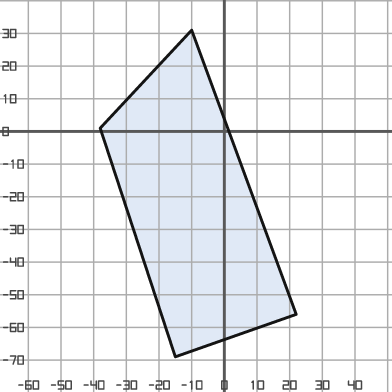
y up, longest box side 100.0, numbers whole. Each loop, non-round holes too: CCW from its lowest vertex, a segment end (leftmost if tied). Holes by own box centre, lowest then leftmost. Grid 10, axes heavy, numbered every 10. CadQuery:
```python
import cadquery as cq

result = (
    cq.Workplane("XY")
    .moveTo(-15.0, -69.0)
    .lineTo(22.0, -56.0)
    .lineTo(-10.0, 31.0)
    .lineTo(-38.0, 1.0)
    .close()
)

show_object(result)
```